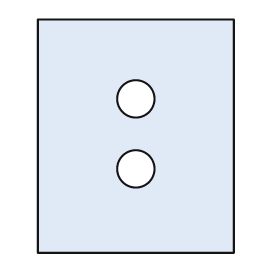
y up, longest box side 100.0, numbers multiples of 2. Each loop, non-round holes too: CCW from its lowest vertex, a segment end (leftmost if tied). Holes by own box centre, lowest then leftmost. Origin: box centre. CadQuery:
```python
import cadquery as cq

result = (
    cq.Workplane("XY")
    .moveTo(-42.0, -50.0)
    .lineTo(42.0, -50.0)
    .lineTo(42.0, 50.0)
    .lineTo(-42.0, 50.0)
    .close()
    .moveTo(0.0, -14.0)
    .circle(8.0)
    .moveTo(0.0, 16.0)
    .circle(8.0)
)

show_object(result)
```